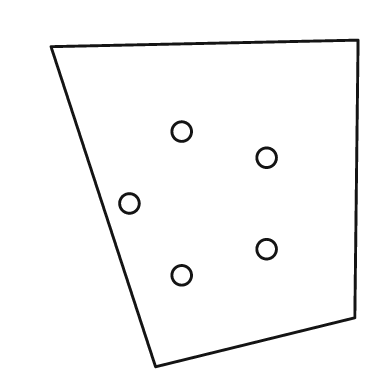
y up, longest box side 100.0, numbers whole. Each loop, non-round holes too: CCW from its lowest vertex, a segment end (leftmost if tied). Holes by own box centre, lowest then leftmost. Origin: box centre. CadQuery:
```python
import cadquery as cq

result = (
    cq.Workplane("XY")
    .moveTo(-15.0, -50.0)
    .lineTo(46.0, -35.0)
    .lineTo(47.0, 50.0)
    .lineTo(-47.0, 48.0)
    .close()
    .moveTo(-7.0, -22.0)
    .circle(3.0)
    .moveTo(19.0, -14.0)
    .circle(3.0)
    .moveTo(-23.0, 0.0)
    .circle(3.0)
    .moveTo(19.0, 14.0)
    .circle(3.0)
    .moveTo(-7.0, 22.0)
    .circle(3.0)
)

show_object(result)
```